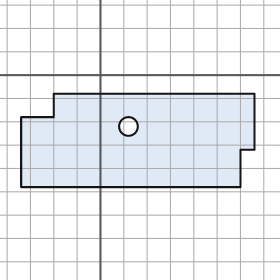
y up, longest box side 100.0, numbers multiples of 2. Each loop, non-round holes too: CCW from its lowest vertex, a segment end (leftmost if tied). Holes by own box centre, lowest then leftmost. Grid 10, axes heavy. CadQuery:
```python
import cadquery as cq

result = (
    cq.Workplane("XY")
    .moveTo(-34.0, -48.0)
    .lineTo(60.0, -48.0)
    .lineTo(60.0, -32.0)
    .lineTo(66.0, -32.0)
    .lineTo(66.0, -8.0)
    .lineTo(-20.0, -8.0)
    .lineTo(-20.0, -18.0)
    .lineTo(-34.0, -18.0)
    .close()
    .moveTo(12.0, -22.0)
    .circle(4.0)
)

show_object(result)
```